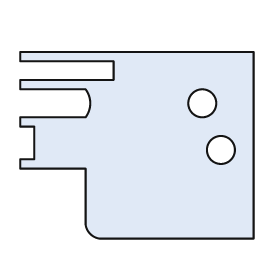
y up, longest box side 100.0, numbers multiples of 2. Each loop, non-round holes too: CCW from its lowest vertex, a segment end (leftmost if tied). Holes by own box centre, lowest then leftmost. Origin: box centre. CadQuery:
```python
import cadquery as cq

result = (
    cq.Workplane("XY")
    .moveTo(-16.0, -40.0)
    .lineTo(50.0, -40.0)
    .lineTo(50.0, 40.0)
    .lineTo(-50.0, 40.0)
    .lineTo(-50.0, 36.0)
    .lineTo(-10.0, 36.0)
    .lineTo(-10.0, 28.0)
    .lineTo(-50.0, 28.0)
    .lineTo(-50.0, 24.0)
    .lineTo(-22.0, 24.0)
    .threePointArc((-20.0, 18.0), (-22.0, 12.0))
    .lineTo(-50.0, 12.0)
    .lineTo(-50.0, 8.0)
    .lineTo(-44.0, 8.0)
    .lineTo(-44.0, -6.0)
    .lineTo(-50.0, -6.0)
    .lineTo(-50.0, -10.0)
    .lineTo(-22.0, -10.0)
    .lineTo(-22.0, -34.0)
    .threePointArc((-20.0, -38.0), (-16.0, -40.0))
    .close()
    .moveTo(36.0, -2.0)
    .circle(6.0)
    .moveTo(28.0, 18.0)
    .circle(6.0)
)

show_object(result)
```